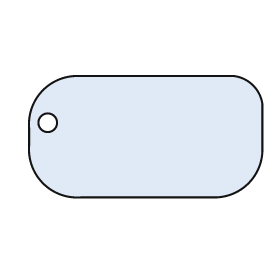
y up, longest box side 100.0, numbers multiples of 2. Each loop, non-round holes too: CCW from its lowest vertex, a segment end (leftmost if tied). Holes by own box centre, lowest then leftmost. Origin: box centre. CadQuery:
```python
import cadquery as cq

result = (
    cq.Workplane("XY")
    .moveTo(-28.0, -26.0)
    .lineTo(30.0, -26.0)
    .threePointArc((44.0, -20.0), (50.0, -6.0))
    .lineTo(50.0, 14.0)
    .threePointArc((46.0, 22.0), (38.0, 26.0))
    .lineTo(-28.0, 26.0)
    .threePointArc((-44.0, 20.0), (-50.0, 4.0))
    .lineTo(-50.0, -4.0)
    .threePointArc((-44.0, -20.0), (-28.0, -26.0))
    .close()
    .moveTo(-42.0, 6.0)
    .circle(4.0)
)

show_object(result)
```